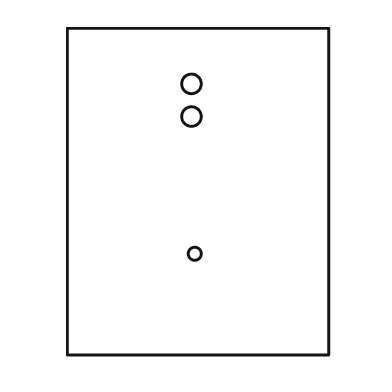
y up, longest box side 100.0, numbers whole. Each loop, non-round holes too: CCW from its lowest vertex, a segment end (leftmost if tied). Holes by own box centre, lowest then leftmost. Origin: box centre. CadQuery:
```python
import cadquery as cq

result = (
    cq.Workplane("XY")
    .moveTo(-40.0, -50.0)
    .lineTo(40.0, -50.0)
    .lineTo(40.0, 50.0)
    .lineTo(-40.0, 50.0)
    .close()
    .moveTo(-1.0, -19.0)
    .circle(2.0)
    .moveTo(-2.0, 23.0)
    .circle(3.0)
    .moveTo(-2.0, 33.0)
    .circle(3.0)
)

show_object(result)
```